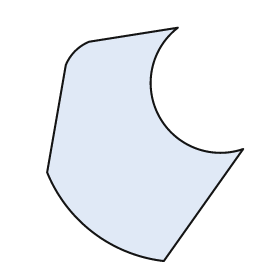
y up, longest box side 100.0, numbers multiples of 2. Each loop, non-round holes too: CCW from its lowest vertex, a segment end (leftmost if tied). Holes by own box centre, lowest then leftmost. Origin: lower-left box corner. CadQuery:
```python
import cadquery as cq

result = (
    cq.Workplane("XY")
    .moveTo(50.0, 0.0)
    .lineTo(84.0, 48.0)
    .threePointArc((48.0, 62.0), (56.0, 100.0))
    .lineTo(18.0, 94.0)
    .threePointArc((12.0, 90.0), (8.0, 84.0))
    .lineTo(0.0, 38.0)
    .threePointArc((20.0, 12.0), (50.0, 0.0))
    .close()
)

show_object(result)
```